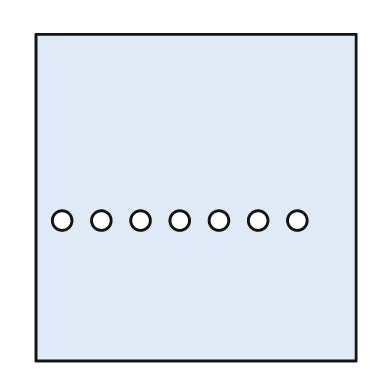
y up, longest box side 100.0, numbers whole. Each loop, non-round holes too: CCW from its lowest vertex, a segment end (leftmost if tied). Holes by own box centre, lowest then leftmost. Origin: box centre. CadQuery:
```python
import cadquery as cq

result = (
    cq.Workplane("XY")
    .moveTo(-49.0, -50.0)
    .lineTo(49.0, -50.0)
    .lineTo(49.0, 50.0)
    .lineTo(-49.0, 50.0)
    .close()
    .moveTo(-41.0, -7.0)
    .circle(3.0)
    .moveTo(-29.0, -7.0)
    .circle(3.0)
    .moveTo(-17.0, -7.0)
    .circle(3.0)
    .moveTo(-5.0, -7.0)
    .circle(3.0)
    .moveTo(7.0, -7.0)
    .circle(3.0)
    .moveTo(19.0, -7.0)
    .circle(3.0)
    .moveTo(31.0, -7.0)
    .circle(3.0)
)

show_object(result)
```